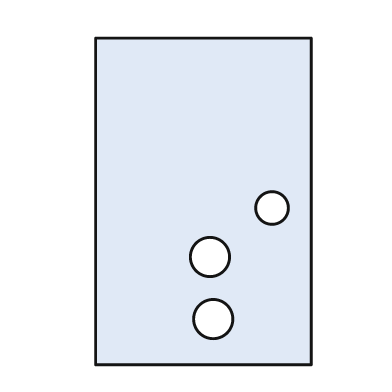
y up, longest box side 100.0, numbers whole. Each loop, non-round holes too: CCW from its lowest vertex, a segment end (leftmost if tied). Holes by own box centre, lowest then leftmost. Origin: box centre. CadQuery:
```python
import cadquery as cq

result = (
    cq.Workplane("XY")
    .moveTo(-33.0, -50.0)
    .lineTo(33.0, -50.0)
    .lineTo(33.0, 50.0)
    .lineTo(-33.0, 50.0)
    .close()
    .moveTo(3.0, -36.0)
    .circle(6.0)
    .moveTo(2.0, -17.0)
    .circle(6.0)
    .moveTo(21.0, -2.0)
    .circle(5.0)
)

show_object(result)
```